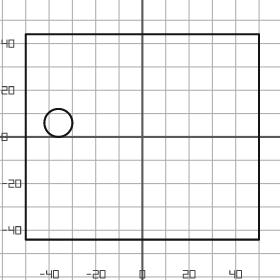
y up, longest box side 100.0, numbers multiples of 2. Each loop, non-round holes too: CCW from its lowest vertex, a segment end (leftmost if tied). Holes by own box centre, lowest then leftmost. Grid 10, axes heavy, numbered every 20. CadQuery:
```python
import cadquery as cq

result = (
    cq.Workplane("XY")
    .moveTo(-50.0, -44.0)
    .lineTo(50.0, -44.0)
    .lineTo(50.0, 44.0)
    .lineTo(-50.0, 44.0)
    .close()
    .moveTo(-36.0, 6.0)
    .circle(6.0)
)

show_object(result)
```